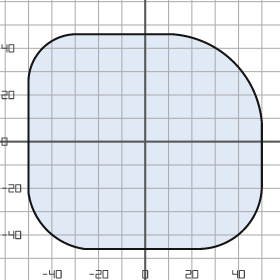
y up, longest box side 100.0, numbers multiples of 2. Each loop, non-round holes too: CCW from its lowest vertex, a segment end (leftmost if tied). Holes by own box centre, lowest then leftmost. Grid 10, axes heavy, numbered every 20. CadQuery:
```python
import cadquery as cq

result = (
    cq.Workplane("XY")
    .moveTo(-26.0, -46.0)
    .lineTo(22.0, -46.0)
    .threePointArc((42.0, -38.0), (50.0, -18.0))
    .lineTo(50.0, 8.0)
    .threePointArc((38.0, 34.0), (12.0, 46.0))
    .lineTo(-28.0, 46.0)
    .threePointArc((-44.0, 40.0), (-50.0, 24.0))
    .lineTo(-50.0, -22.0)
    .threePointArc((-42.0, -38.0), (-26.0, -46.0))
    .close()
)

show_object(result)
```